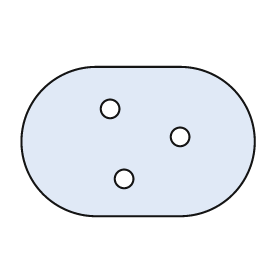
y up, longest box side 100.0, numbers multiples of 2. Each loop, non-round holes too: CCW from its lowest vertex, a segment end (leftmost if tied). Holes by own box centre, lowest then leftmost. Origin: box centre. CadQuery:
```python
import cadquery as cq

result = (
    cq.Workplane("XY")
    .moveTo(-18.0, -32.0)
    .lineTo(18.0, -32.0)
    .threePointArc((50.0, 0.0), (18.0, 32.0))
    .lineTo(-18.0, 32.0)
    .threePointArc((-50.0, 0.0), (-18.0, -32.0))
    .close()
    .moveTo(-6.0, -16.0)
    .circle(4.0)
    .moveTo(18.0, 2.0)
    .circle(4.0)
    .moveTo(-12.0, 14.0)
    .circle(4.0)
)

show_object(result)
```